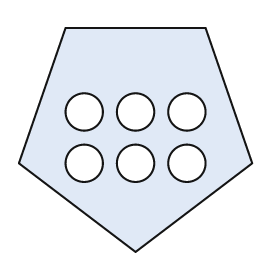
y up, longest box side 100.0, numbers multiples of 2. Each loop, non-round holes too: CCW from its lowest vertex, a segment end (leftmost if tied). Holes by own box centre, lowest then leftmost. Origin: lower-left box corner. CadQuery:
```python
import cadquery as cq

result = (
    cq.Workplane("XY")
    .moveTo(50.0, 0.0)
    .lineTo(100.0, 38.0)
    .lineTo(80.0, 96.0)
    .lineTo(20.0, 96.0)
    .lineTo(0.0, 38.0)
    .close()
    .moveTo(28.0, 38.0)
    .circle(8.0)
    .moveTo(50.0, 38.0)
    .circle(8.0)
    .moveTo(72.0, 38.0)
    .circle(8.0)
    .moveTo(28.0, 60.0)
    .circle(8.0)
    .moveTo(50.0, 60.0)
    .circle(8.0)
    .moveTo(72.0, 60.0)
    .circle(8.0)
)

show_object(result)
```